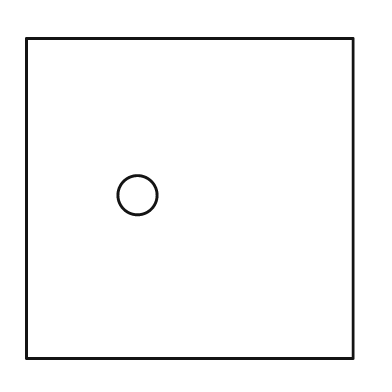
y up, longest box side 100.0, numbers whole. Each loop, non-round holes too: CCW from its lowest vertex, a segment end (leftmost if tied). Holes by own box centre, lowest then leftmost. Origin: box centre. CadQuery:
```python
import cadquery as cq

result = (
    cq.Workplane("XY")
    .moveTo(-50.0, -49.0)
    .lineTo(50.0, -49.0)
    .lineTo(50.0, 49.0)
    .lineTo(-50.0, 49.0)
    .close()
    .moveTo(-16.0, 1.0)
    .circle(6.0)
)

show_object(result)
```